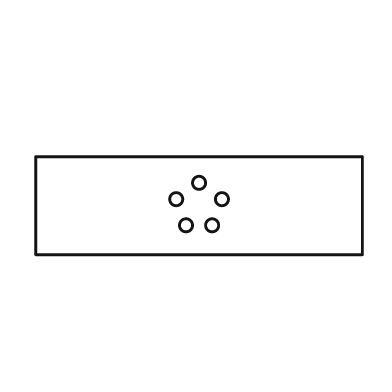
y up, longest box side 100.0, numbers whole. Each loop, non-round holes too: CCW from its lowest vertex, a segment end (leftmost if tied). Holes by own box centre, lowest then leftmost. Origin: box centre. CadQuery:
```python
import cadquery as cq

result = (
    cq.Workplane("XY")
    .moveTo(-50.0, -15.0)
    .lineTo(50.0, -15.0)
    .lineTo(50.0, 15.0)
    .lineTo(-50.0, 15.0)
    .close()
    .moveTo(-4.0, -6.0)
    .circle(2.0)
    .moveTo(4.0, -6.0)
    .circle(2.0)
    .moveTo(-7.0, 2.0)
    .circle(2.0)
    .moveTo(7.0, 2.0)
    .circle(2.0)
    .moveTo(0.0, 7.0)
    .circle(2.0)
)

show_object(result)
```